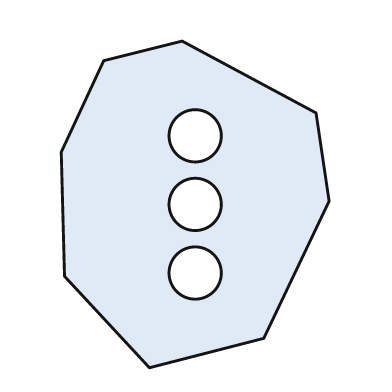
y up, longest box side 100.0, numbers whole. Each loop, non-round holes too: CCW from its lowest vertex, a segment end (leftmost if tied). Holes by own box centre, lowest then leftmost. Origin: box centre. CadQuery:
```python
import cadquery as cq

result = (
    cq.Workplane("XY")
    .moveTo(-14.0, -50.0)
    .lineTo(21.0, -41.0)
    .lineTo(41.0, 1.0)
    .lineTo(37.0, 28.0)
    .lineTo(-4.0, 50.0)
    .lineTo(-28.0, 44.0)
    .lineTo(-41.0, 16.0)
    .lineTo(-40.0, -22.0)
    .close()
    .moveTo(0.0, -21.0)
    .circle(8.0)
    .moveTo(0.0, 0.0)
    .circle(8.0)
    .moveTo(0.0, 21.0)
    .circle(8.0)
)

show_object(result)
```